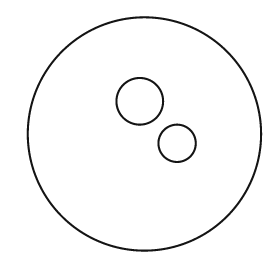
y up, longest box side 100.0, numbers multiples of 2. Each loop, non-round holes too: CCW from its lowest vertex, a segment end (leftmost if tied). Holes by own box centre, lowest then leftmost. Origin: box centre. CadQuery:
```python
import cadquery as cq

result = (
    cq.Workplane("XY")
    .moveTo(0.0, 0.0)
    .circle(50.0)
    .moveTo(14.0, -4.0)
    .circle(8.0)
    .moveTo(-2.0, 14.0)
    .circle(10.0)
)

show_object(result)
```